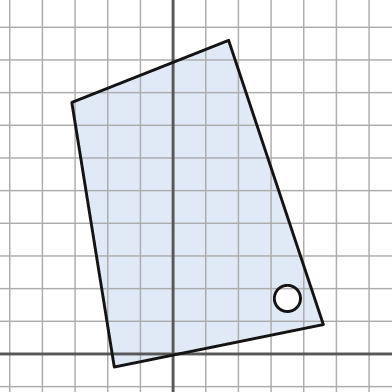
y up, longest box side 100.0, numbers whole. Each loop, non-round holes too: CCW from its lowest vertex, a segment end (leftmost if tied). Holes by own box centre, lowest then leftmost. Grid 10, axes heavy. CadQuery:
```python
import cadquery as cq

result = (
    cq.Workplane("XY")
    .moveTo(-18.0, -4.0)
    .lineTo(46.0, 9.0)
    .lineTo(17.0, 96.0)
    .lineTo(-31.0, 77.0)
    .close()
    .moveTo(35.0, 17.0)
    .circle(4.0)
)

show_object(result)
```